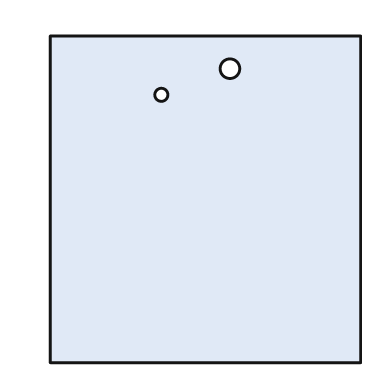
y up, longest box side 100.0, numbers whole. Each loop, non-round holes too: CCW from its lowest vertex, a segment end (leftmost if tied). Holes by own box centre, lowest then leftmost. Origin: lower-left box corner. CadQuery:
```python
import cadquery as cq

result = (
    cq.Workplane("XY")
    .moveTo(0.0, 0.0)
    .lineTo(95.0, 0.0)
    .lineTo(95.0, 100.0)
    .lineTo(0.0, 100.0)
    .close()
    .moveTo(34.0, 82.0)
    .circle(2.0)
    .moveTo(55.0, 90.0)
    .circle(3.0)
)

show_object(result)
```